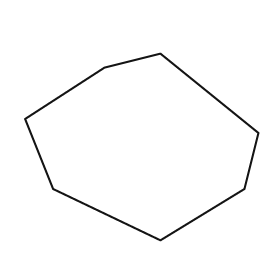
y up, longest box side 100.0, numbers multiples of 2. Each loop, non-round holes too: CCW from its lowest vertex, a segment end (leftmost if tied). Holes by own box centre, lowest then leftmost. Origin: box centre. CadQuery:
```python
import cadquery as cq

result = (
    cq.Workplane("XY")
    .moveTo(8.0, -40.0)
    .lineTo(44.0, -18.0)
    .lineTo(50.0, 6.0)
    .lineTo(8.0, 40.0)
    .lineTo(-16.0, 34.0)
    .lineTo(-50.0, 12.0)
    .lineTo(-38.0, -18.0)
    .close()
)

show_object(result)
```